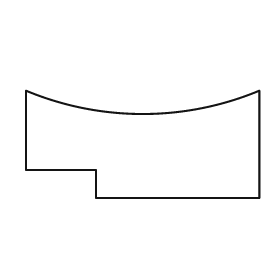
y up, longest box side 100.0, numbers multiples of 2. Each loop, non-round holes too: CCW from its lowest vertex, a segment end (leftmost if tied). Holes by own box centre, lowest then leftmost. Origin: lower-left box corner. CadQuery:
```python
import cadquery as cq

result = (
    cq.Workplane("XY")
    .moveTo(30.0, 0.0)
    .lineTo(100.0, 0.0)
    .lineTo(100.0, 46.0)
    .threePointArc((50.0, 36.0), (0.0, 46.0))
    .lineTo(0.0, 12.0)
    .lineTo(30.0, 12.0)
    .close()
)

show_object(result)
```